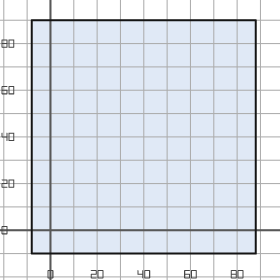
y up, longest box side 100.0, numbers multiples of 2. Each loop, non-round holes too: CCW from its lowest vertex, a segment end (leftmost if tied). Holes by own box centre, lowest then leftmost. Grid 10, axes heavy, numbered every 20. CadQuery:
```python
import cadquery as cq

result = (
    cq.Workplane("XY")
    .moveTo(-8.0, -10.0)
    .lineTo(88.0, -10.0)
    .lineTo(88.0, 90.0)
    .lineTo(-8.0, 90.0)
    .close()
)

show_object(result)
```